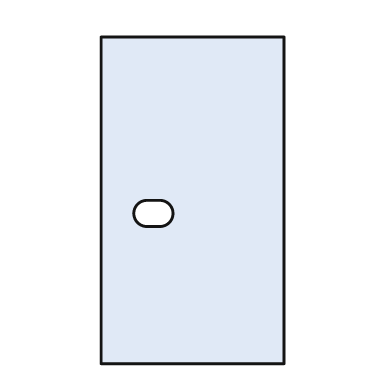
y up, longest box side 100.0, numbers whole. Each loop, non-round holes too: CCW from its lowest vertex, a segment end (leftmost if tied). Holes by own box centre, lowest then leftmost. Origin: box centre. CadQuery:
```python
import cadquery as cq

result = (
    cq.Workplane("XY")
    .moveTo(-28.0, -50.0)
    .lineTo(28.0, -50.0)
    .lineTo(28.0, 50.0)
    .lineTo(-28.0, 50.0)
    .close()
    .moveTo(-14.0, -8.0)
    .lineTo(-10.0, -8.0)
    .threePointArc((-6.0, -4.0), (-10.0, 0.0))
    .lineTo(-14.0, 0.0)
    .threePointArc((-18.0, -4.0), (-14.0, -8.0))
    .close()
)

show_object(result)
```